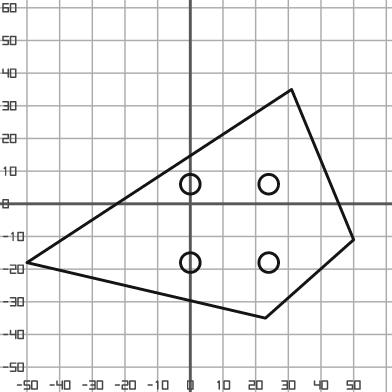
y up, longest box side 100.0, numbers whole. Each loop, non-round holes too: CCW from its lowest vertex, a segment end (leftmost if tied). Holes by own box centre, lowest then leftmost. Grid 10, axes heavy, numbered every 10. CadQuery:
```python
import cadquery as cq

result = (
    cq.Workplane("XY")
    .moveTo(23.0, -35.0)
    .lineTo(50.0, -11.0)
    .lineTo(31.0, 35.0)
    .lineTo(-50.0, -18.0)
    .close()
    .moveTo(0.0, -18.0)
    .circle(3.0)
    .moveTo(24.0, -18.0)
    .circle(3.0)
    .moveTo(0.0, 6.0)
    .circle(3.0)
    .moveTo(24.0, 6.0)
    .circle(3.0)
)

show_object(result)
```